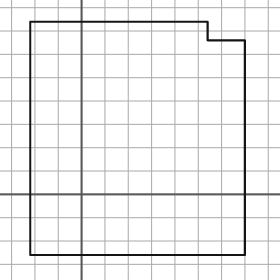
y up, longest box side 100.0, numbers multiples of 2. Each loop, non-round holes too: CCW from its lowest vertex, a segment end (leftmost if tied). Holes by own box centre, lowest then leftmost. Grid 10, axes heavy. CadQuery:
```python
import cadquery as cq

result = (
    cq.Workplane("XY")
    .moveTo(-22.0, -26.0)
    .lineTo(70.0, -26.0)
    .lineTo(70.0, 66.0)
    .lineTo(54.0, 66.0)
    .lineTo(54.0, 74.0)
    .lineTo(-22.0, 74.0)
    .close()
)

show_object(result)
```